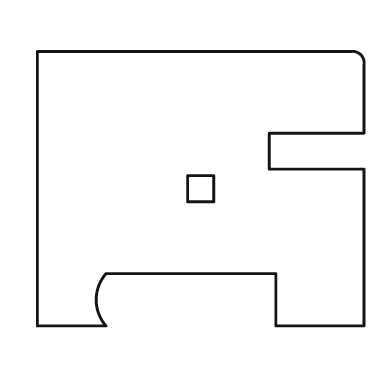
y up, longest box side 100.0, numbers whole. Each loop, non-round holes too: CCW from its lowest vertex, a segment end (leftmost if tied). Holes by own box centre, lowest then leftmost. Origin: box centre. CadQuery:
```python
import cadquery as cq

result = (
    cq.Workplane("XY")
    .moveTo(-50.0, -42.0)
    .lineTo(-29.0, -42.0)
    .threePointArc((-32.0, -34.0), (-29.0, -26.0))
    .lineTo(23.0, -26.0)
    .lineTo(23.0, -42.0)
    .lineTo(50.0, -42.0)
    .lineTo(50.0, 6.0)
    .lineTo(21.0, 6.0)
    .lineTo(21.0, 17.0)
    .lineTo(50.0, 17.0)
    .lineTo(50.0, 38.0)
    .threePointArc((49.0, 41.0), (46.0, 42.0))
    .lineTo(-50.0, 42.0)
    .close()
    .moveTo(-4.0, -4.0)
    .lineTo(4.0, -4.0)
    .lineTo(4.0, 4.0)
    .lineTo(-4.0, 4.0)
    .close()
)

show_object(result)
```